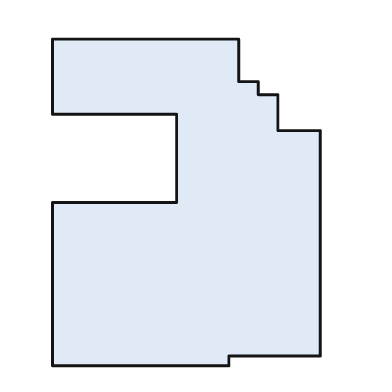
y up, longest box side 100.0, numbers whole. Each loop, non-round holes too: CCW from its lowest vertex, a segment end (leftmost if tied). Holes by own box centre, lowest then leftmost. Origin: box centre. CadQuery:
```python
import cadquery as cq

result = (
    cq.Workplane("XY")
    .moveTo(-41.0, -50.0)
    .lineTo(13.0, -50.0)
    .lineTo(13.0, -47.0)
    .lineTo(41.0, -47.0)
    .lineTo(41.0, 22.0)
    .lineTo(28.0, 22.0)
    .lineTo(28.0, 33.0)
    .lineTo(22.0, 33.0)
    .lineTo(22.0, 37.0)
    .lineTo(16.0, 37.0)
    .lineTo(16.0, 50.0)
    .lineTo(-41.0, 50.0)
    .lineTo(-41.0, 27.0)
    .lineTo(-3.0, 27.0)
    .lineTo(-3.0, 0.0)
    .lineTo(-41.0, 0.0)
    .close()
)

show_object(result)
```